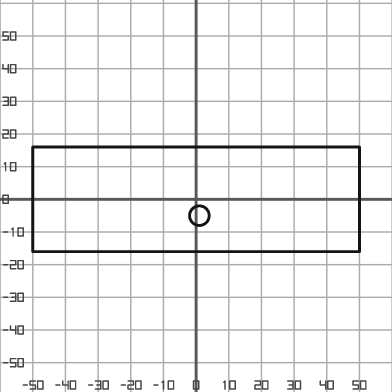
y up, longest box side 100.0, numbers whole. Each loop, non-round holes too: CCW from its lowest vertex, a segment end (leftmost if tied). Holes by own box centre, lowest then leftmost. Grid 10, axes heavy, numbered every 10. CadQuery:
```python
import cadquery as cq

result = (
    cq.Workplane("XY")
    .moveTo(-50.0, -16.0)
    .lineTo(50.0, -16.0)
    .lineTo(50.0, 16.0)
    .lineTo(-50.0, 16.0)
    .close()
    .moveTo(1.0, -5.0)
    .circle(3.0)
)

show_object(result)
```